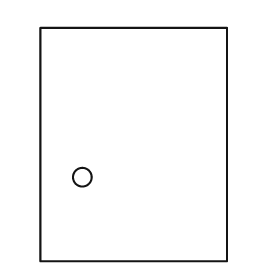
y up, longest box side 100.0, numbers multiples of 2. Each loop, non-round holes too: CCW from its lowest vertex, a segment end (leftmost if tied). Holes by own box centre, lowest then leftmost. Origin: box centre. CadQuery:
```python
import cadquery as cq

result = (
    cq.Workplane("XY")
    .moveTo(-40.0, -50.0)
    .lineTo(40.0, -50.0)
    .lineTo(40.0, 50.0)
    .lineTo(-40.0, 50.0)
    .close()
    .moveTo(-22.0, -14.0)
    .circle(4.0)
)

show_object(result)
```